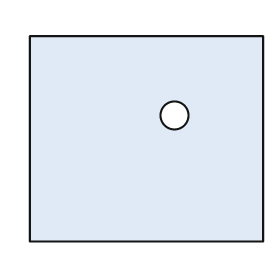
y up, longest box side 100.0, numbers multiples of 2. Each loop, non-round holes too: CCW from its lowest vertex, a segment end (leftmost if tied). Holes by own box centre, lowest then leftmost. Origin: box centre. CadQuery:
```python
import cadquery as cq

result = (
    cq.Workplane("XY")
    .moveTo(-50.0, -44.0)
    .lineTo(50.0, -44.0)
    .lineTo(50.0, 44.0)
    .lineTo(-50.0, 44.0)
    .close()
    .moveTo(12.0, 10.0)
    .circle(6.0)
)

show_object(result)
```